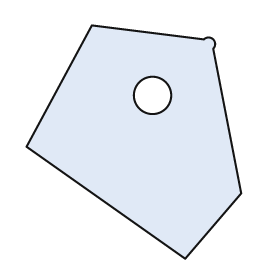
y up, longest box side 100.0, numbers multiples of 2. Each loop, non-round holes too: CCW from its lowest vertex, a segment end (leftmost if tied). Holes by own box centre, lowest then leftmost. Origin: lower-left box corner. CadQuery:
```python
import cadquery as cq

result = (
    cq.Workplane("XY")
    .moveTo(68.0, 0.0)
    .lineTo(92.0, 28.0)
    .lineTo(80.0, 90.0)
    .threePointArc((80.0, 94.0), (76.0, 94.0))
    .lineTo(28.0, 100.0)
    .lineTo(0.0, 48.0)
    .close()
    .moveTo(54.0, 70.0)
    .circle(8.0)
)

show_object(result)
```